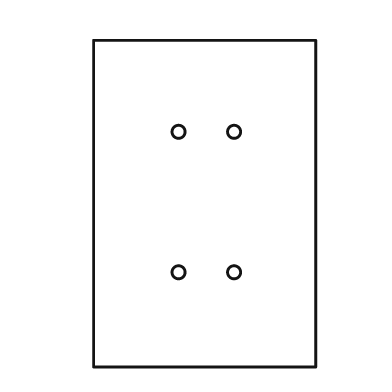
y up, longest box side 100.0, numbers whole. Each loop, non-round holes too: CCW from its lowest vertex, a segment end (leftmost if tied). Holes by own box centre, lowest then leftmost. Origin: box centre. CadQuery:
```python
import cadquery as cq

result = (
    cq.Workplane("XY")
    .moveTo(-34.0, -50.0)
    .lineTo(34.0, -50.0)
    .lineTo(34.0, 50.0)
    .lineTo(-34.0, 50.0)
    .close()
    .moveTo(-8.0, -21.0)
    .circle(2.0)
    .moveTo(9.0, -21.0)
    .circle(2.0)
    .moveTo(-8.0, 22.0)
    .circle(2.0)
    .moveTo(9.0, 22.0)
    .circle(2.0)
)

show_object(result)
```